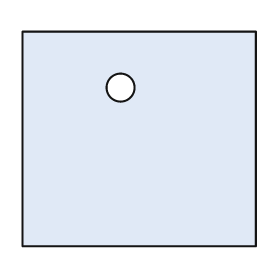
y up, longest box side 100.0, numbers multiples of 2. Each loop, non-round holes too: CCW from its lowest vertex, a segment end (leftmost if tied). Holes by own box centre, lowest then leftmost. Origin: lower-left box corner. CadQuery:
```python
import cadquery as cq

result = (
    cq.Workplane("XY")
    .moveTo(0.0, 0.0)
    .lineTo(100.0, 0.0)
    .lineTo(100.0, 92.0)
    .lineTo(0.0, 92.0)
    .close()
    .moveTo(42.0, 68.0)
    .circle(6.0)
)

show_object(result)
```